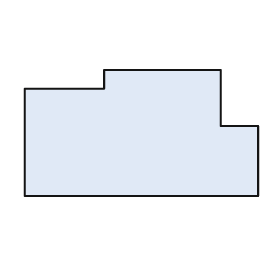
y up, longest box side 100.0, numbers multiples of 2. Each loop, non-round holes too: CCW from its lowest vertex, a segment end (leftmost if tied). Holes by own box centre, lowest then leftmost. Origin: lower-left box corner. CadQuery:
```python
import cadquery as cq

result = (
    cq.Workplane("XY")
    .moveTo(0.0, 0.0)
    .lineTo(100.0, 0.0)
    .lineTo(100.0, 30.0)
    .lineTo(84.0, 30.0)
    .lineTo(84.0, 54.0)
    .lineTo(34.0, 54.0)
    .lineTo(34.0, 46.0)
    .lineTo(0.0, 46.0)
    .close()
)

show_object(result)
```